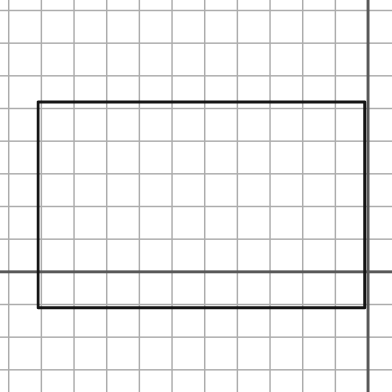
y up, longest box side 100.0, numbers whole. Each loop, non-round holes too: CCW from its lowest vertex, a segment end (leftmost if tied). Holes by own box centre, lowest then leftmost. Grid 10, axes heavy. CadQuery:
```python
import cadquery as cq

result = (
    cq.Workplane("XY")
    .moveTo(-101.0, -11.0)
    .lineTo(-1.0, -11.0)
    .lineTo(-1.0, 52.0)
    .lineTo(-101.0, 52.0)
    .close()
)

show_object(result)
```